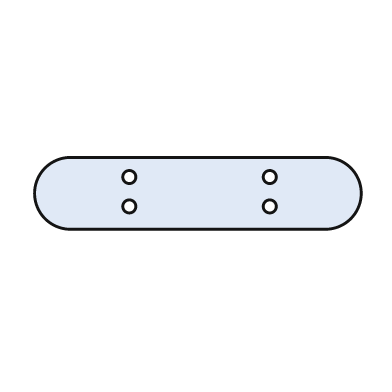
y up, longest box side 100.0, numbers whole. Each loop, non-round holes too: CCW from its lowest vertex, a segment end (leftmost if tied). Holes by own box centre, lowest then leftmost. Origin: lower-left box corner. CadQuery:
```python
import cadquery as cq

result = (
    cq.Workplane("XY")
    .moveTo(11.0, 0.0)
    .lineTo(89.0, 0.0)
    .threePointArc((100.0, 11.0), (89.0, 22.0))
    .lineTo(11.0, 22.0)
    .threePointArc((0.0, 11.0), (11.0, 0.0))
    .close()
    .moveTo(29.0, 7.0)
    .circle(2.0)
    .moveTo(72.0, 7.0)
    .circle(2.0)
    .moveTo(29.0, 16.0)
    .circle(2.0)
    .moveTo(72.0, 16.0)
    .circle(2.0)
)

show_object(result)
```